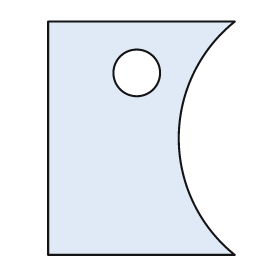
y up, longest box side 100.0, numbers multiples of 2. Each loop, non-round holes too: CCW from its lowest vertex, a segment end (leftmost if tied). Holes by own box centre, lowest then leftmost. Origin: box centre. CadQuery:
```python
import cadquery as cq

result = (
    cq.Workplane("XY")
    .moveTo(-40.0, -50.0)
    .lineTo(40.0, -50.0)
    .threePointArc((16.0, 0.0), (40.0, 50.0))
    .lineTo(-40.0, 50.0)
    .close()
    .moveTo(-2.0, 28.0)
    .circle(10.0)
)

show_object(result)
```